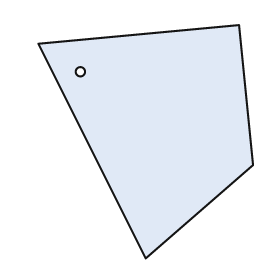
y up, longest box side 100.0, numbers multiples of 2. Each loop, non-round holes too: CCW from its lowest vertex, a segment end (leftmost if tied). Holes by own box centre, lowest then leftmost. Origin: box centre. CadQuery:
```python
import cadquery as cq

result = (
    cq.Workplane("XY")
    .moveTo(0.0, -50.0)
    .lineTo(46.0, -10.0)
    .lineTo(40.0, 50.0)
    .lineTo(-46.0, 42.0)
    .close()
    .moveTo(-28.0, 30.0)
    .circle(2.0)
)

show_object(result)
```